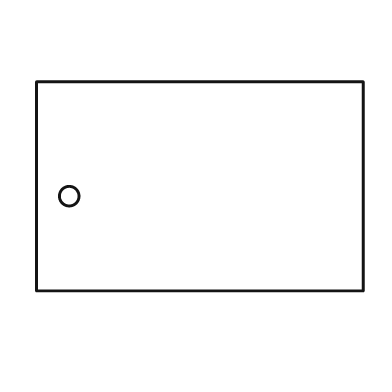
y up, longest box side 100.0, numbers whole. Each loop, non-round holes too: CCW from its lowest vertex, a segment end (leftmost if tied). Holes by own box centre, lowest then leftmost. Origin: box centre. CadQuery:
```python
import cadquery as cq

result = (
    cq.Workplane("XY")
    .moveTo(-50.0, -32.0)
    .lineTo(50.0, -32.0)
    .lineTo(50.0, 32.0)
    .lineTo(-50.0, 32.0)
    .close()
    .moveTo(-40.0, -3.0)
    .circle(3.0)
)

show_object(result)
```